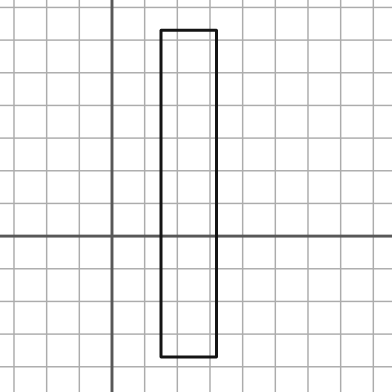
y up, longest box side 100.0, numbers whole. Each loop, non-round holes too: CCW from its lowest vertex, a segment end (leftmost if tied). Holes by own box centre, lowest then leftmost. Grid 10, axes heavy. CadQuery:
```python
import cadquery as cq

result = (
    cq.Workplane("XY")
    .moveTo(15.0, -37.0)
    .lineTo(32.0, -37.0)
    .lineTo(32.0, 63.0)
    .lineTo(15.0, 63.0)
    .close()
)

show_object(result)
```